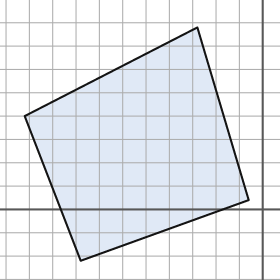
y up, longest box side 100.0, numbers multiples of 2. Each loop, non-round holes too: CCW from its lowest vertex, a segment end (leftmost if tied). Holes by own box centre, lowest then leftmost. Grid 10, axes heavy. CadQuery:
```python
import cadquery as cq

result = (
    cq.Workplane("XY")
    .moveTo(-78.0, -22.0)
    .lineTo(-6.0, 4.0)
    .lineTo(-28.0, 78.0)
    .lineTo(-102.0, 40.0)
    .close()
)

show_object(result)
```